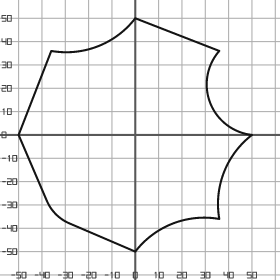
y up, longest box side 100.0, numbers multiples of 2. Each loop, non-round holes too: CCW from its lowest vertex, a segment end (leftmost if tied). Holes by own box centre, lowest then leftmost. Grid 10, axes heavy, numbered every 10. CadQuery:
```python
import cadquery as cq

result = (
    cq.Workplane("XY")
    .moveTo(0.0, -50.0)
    .threePointArc((16.0, -38.0), (36.0, -36.0))
    .threePointArc((38.0, -16.0), (50.0, 0.0))
    .threePointArc((32.0, 14.0), (36.0, 36.0))
    .lineTo(0.0, 50.0)
    .threePointArc((-16.0, 38.0), (-36.0, 36.0))
    .lineTo(-50.0, 0.0)
    .lineTo(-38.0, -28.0)
    .threePointArc((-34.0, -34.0), (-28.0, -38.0))
    .close()
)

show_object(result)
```